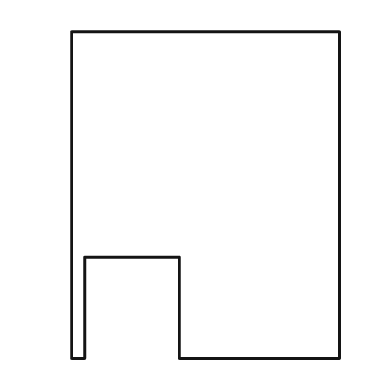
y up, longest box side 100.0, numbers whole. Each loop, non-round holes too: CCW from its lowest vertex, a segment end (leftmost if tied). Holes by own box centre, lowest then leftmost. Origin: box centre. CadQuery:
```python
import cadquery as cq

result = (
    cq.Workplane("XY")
    .moveTo(-41.0, -50.0)
    .lineTo(-37.0, -50.0)
    .lineTo(-37.0, -19.0)
    .lineTo(-8.0, -19.0)
    .lineTo(-8.0, -50.0)
    .lineTo(41.0, -50.0)
    .lineTo(41.0, 50.0)
    .lineTo(-41.0, 50.0)
    .close()
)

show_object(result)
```